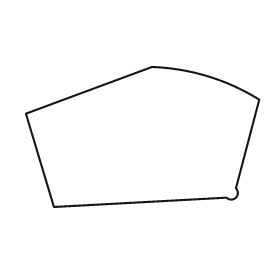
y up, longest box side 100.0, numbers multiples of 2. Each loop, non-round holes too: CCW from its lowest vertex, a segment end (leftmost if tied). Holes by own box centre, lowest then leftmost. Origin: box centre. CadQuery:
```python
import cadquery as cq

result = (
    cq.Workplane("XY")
    .moveTo(-38.0, -30.0)
    .lineTo(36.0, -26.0)
    .threePointArc((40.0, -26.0), (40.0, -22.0))
    .lineTo(50.0, 16.0)
    .threePointArc((28.0, 26.0), (4.0, 30.0))
    .lineTo(-50.0, 10.0)
    .close()
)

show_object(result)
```